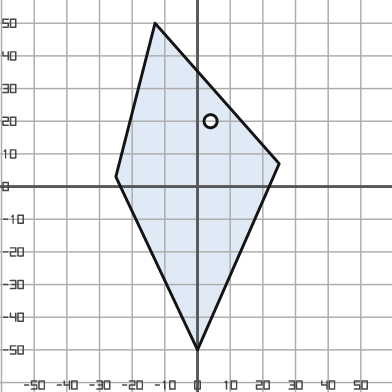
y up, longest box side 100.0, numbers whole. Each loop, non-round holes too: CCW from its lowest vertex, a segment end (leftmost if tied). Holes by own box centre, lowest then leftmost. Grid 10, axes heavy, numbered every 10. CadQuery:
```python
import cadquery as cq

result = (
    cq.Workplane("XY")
    .moveTo(0.0, -50.0)
    .lineTo(25.0, 7.0)
    .lineTo(-13.0, 50.0)
    .lineTo(-25.0, 3.0)
    .close()
    .moveTo(4.0, 20.0)
    .circle(2.0)
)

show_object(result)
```